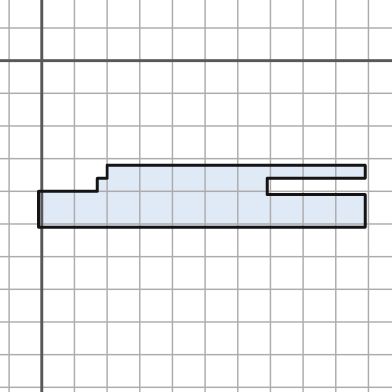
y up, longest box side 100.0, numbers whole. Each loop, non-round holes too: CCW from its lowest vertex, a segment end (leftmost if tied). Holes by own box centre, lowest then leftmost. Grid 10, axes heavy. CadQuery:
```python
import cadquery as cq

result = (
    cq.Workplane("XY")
    .moveTo(-1.0, -51.0)
    .lineTo(99.0, -51.0)
    .lineTo(99.0, -41.0)
    .lineTo(69.0, -41.0)
    .lineTo(69.0, -36.0)
    .lineTo(99.0, -36.0)
    .lineTo(99.0, -32.0)
    .lineTo(20.0, -32.0)
    .lineTo(20.0, -36.0)
    .lineTo(17.0, -36.0)
    .lineTo(17.0, -40.0)
    .lineTo(-1.0, -40.0)
    .close()
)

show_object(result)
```